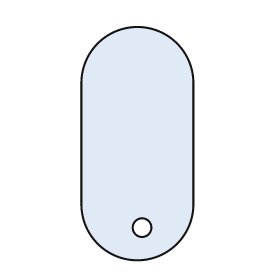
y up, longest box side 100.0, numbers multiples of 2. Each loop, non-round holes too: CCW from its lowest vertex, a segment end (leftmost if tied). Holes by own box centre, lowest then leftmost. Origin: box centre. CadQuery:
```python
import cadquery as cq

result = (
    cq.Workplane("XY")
    .moveTo(-24.0, -26.0)
    .threePointArc((0.0, -50.0), (24.0, -26.0))
    .lineTo(24.0, 26.0)
    .threePointArc((0.0, 50.0), (-24.0, 26.0))
    .close()
    .moveTo(2.0, -36.0)
    .circle(4.0)
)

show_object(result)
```